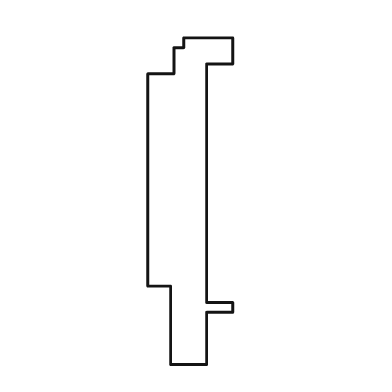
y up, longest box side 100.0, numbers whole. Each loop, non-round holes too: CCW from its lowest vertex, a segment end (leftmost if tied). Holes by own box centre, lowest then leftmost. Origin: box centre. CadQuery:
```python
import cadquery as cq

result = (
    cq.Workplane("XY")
    .moveTo(-6.0, -50.0)
    .lineTo(5.0, -50.0)
    .lineTo(5.0, -34.0)
    .lineTo(13.0, -34.0)
    .lineTo(13.0, -31.0)
    .lineTo(5.0, -31.0)
    .lineTo(5.0, 42.0)
    .lineTo(13.0, 42.0)
    .lineTo(13.0, 50.0)
    .lineTo(-2.0, 50.0)
    .lineTo(-2.0, 47.0)
    .lineTo(-5.0, 47.0)
    .lineTo(-5.0, 39.0)
    .lineTo(-13.0, 39.0)
    .lineTo(-13.0, -26.0)
    .lineTo(-6.0, -26.0)
    .close()
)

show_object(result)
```